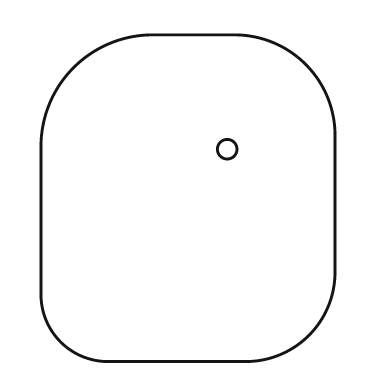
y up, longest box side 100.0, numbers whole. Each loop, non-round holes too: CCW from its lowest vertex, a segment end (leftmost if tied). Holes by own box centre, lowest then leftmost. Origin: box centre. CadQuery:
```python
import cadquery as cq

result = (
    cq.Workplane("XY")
    .moveTo(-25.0, -50.0)
    .lineTo(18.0, -50.0)
    .threePointArc((37.0, -42.0), (45.0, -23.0))
    .lineTo(45.0, 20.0)
    .threePointArc((36.0, 41.0), (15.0, 50.0))
    .lineTo(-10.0, 50.0)
    .threePointArc((-35.0, 40.0), (-45.0, 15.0))
    .lineTo(-45.0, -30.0)
    .threePointArc((-39.0, -44.0), (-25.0, -50.0))
    .close()
    .moveTo(12.0, 15.0)
    .circle(3.0)
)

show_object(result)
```